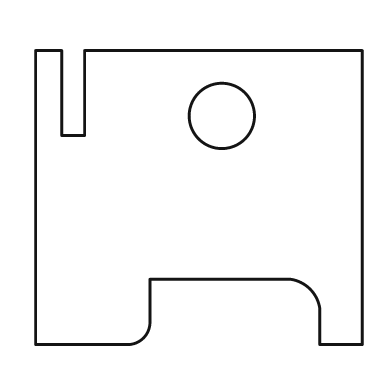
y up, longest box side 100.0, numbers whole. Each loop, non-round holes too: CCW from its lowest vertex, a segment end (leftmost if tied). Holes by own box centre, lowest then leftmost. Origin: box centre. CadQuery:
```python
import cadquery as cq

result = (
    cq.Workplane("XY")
    .moveTo(-50.0, -45.0)
    .lineTo(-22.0, -45.0)
    .threePointArc((-17.0, -43.0), (-15.0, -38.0))
    .lineTo(-15.0, -25.0)
    .lineTo(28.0, -25.0)
    .threePointArc((34.0, -28.0), (37.0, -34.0))
    .lineTo(37.0, -45.0)
    .lineTo(50.0, -45.0)
    .lineTo(50.0, 45.0)
    .lineTo(-35.0, 45.0)
    .lineTo(-35.0, 19.0)
    .lineTo(-42.0, 19.0)
    .lineTo(-42.0, 45.0)
    .lineTo(-50.0, 45.0)
    .close()
    .moveTo(7.0, 25.0)
    .circle(10.0)
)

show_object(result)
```